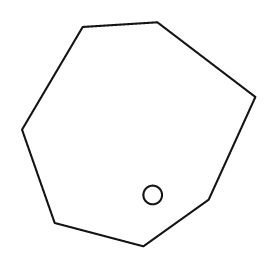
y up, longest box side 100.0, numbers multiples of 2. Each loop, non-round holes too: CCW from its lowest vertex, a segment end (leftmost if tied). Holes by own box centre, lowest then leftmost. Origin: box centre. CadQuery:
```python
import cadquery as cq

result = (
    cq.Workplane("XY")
    .moveTo(2.0, -48.0)
    .lineTo(30.0, -28.0)
    .lineTo(50.0, 16.0)
    .lineTo(8.0, 48.0)
    .lineTo(-24.0, 46.0)
    .lineTo(-50.0, 2.0)
    .lineTo(-36.0, -38.0)
    .close()
    .moveTo(6.0, -26.0)
    .circle(4.0)
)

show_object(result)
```